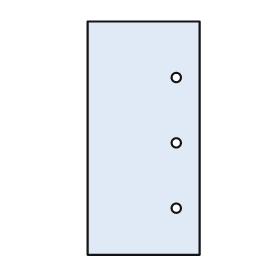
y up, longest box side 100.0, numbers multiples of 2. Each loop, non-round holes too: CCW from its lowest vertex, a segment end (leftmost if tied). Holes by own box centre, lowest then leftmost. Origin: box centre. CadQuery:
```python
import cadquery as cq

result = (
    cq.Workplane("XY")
    .moveTo(-24.0, -50.0)
    .lineTo(24.0, -50.0)
    .lineTo(24.0, 50.0)
    .lineTo(-24.0, 50.0)
    .close()
    .moveTo(14.0, -30.0)
    .circle(2.0)
    .moveTo(14.0, -2.0)
    .circle(2.0)
    .moveTo(14.0, 26.0)
    .circle(2.0)
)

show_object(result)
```